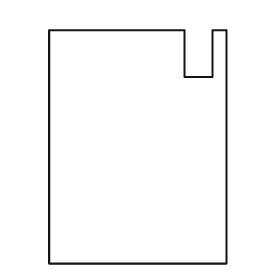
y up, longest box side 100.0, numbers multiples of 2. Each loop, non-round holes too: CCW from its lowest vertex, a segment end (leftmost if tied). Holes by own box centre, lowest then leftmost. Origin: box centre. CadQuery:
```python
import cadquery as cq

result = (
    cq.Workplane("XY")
    .moveTo(-38.0, -50.0)
    .lineTo(38.0, -50.0)
    .lineTo(38.0, 50.0)
    .lineTo(32.0, 50.0)
    .lineTo(32.0, 30.0)
    .lineTo(20.0, 30.0)
    .lineTo(20.0, 50.0)
    .lineTo(-38.0, 50.0)
    .close()
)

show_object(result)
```